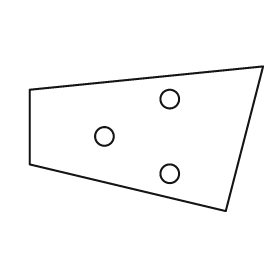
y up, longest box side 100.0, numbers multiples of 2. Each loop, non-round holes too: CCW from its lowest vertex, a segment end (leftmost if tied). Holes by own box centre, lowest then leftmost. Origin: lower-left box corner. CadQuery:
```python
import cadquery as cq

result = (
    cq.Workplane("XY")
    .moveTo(84.0, 0.0)
    .lineTo(100.0, 62.0)
    .lineTo(0.0, 52.0)
    .lineTo(0.0, 20.0)
    .close()
    .moveTo(60.0, 16.0)
    .circle(4.0)
    .moveTo(32.0, 32.0)
    .circle(4.0)
    .moveTo(60.0, 48.0)
    .circle(4.0)
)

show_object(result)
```